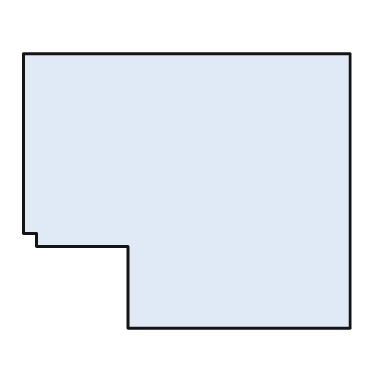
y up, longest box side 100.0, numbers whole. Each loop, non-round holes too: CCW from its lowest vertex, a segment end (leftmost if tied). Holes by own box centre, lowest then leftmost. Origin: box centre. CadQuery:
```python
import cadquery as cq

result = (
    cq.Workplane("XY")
    .moveTo(-18.0, -42.0)
    .lineTo(50.0, -42.0)
    .lineTo(50.0, 42.0)
    .lineTo(-50.0, 42.0)
    .lineTo(-50.0, -13.0)
    .lineTo(-46.0, -13.0)
    .lineTo(-46.0, -17.0)
    .lineTo(-18.0, -17.0)
    .close()
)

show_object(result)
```